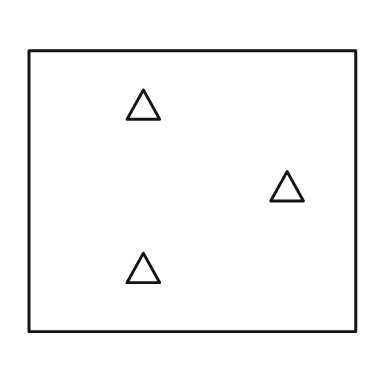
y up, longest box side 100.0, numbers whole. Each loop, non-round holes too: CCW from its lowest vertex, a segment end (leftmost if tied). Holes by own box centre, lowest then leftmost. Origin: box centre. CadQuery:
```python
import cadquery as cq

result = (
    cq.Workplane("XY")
    .moveTo(-50.0, -43.0)
    .lineTo(50.0, -43.0)
    .lineTo(50.0, 43.0)
    .lineTo(-50.0, 43.0)
    .close()
    .moveTo(-20.0, -28.0)
    .lineTo(-10.0, -28.0)
    .lineTo(-15.0, -19.0)
    .close()
    .moveTo(24.0, -3.0)
    .lineTo(34.0, -3.0)
    .lineTo(29.0, 6.0)
    .close()
    .moveTo(-20.0, 22.0)
    .lineTo(-10.0, 22.0)
    .lineTo(-15.0, 31.0)
    .close()
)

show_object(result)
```